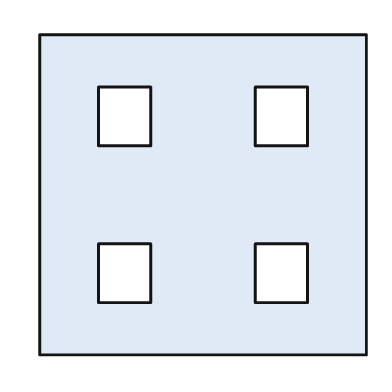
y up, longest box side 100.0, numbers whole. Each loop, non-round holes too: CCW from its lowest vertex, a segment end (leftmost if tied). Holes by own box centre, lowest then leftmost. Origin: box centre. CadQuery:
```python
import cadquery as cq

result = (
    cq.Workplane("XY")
    .moveTo(-50.0, -49.0)
    .lineTo(50.0, -49.0)
    .lineTo(50.0, 49.0)
    .lineTo(-50.0, 49.0)
    .close()
    .moveTo(-32.0, -33.0)
    .lineTo(-16.0, -33.0)
    .lineTo(-16.0, -15.0)
    .lineTo(-32.0, -15.0)
    .close()
    .moveTo(16.0, -33.0)
    .lineTo(32.0, -33.0)
    .lineTo(32.0, -15.0)
    .lineTo(16.0, -15.0)
    .close()
    .moveTo(-32.0, 15.0)
    .lineTo(-16.0, 15.0)
    .lineTo(-16.0, 33.0)
    .lineTo(-32.0, 33.0)
    .close()
    .moveTo(16.0, 15.0)
    .lineTo(32.0, 15.0)
    .lineTo(32.0, 33.0)
    .lineTo(16.0, 33.0)
    .close()
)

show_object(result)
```